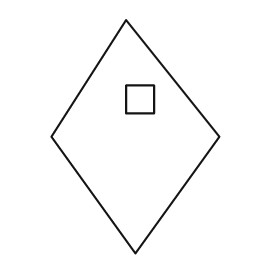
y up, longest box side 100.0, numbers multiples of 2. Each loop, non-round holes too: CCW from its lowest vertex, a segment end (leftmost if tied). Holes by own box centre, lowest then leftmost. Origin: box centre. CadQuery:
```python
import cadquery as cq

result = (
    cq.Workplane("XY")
    .moveTo(0.0, -50.0)
    .lineTo(36.0, 0.0)
    .lineTo(-4.0, 50.0)
    .lineTo(-36.0, 0.0)
    .close()
    .moveTo(-4.0, 10.0)
    .lineTo(8.0, 10.0)
    .lineTo(8.0, 22.0)
    .lineTo(-4.0, 22.0)
    .close()
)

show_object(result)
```